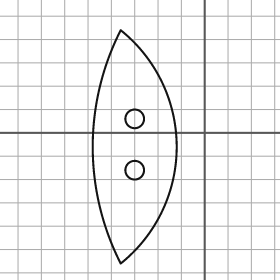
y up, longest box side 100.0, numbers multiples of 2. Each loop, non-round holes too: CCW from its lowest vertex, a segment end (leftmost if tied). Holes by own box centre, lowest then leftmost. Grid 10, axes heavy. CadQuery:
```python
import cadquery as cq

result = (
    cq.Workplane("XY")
    .moveTo(-36.0, -56.0)
    .threePointArc((-12.0, -6.0), (-36.0, 44.0))
    .threePointArc((-48.0, -6.0), (-36.0, -56.0))
    .close()
    .moveTo(-30.0, -16.0)
    .circle(4.0)
    .moveTo(-30.0, 6.0)
    .circle(4.0)
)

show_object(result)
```